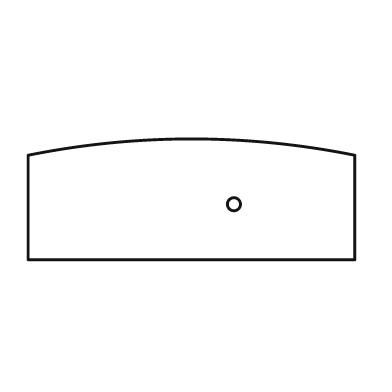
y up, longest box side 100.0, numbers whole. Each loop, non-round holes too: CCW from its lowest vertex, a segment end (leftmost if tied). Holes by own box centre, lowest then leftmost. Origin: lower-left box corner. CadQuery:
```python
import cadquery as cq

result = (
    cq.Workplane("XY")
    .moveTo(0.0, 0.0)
    .lineTo(100.0, 0.0)
    .lineTo(100.0, 32.0)
    .threePointArc((50.0, 37.0), (0.0, 32.0))
    .close()
    .moveTo(63.0, 17.0)
    .circle(2.0)
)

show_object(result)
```